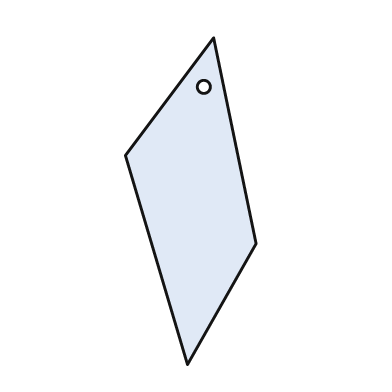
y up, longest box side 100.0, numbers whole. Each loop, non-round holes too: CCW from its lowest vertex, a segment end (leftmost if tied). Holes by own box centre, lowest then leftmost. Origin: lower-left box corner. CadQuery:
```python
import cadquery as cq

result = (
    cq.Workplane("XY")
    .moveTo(19.0, 0.0)
    .lineTo(40.0, 37.0)
    .lineTo(27.0, 100.0)
    .lineTo(0.0, 64.0)
    .close()
    .moveTo(24.0, 85.0)
    .circle(2.0)
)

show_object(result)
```